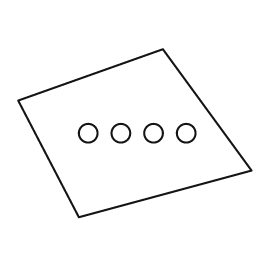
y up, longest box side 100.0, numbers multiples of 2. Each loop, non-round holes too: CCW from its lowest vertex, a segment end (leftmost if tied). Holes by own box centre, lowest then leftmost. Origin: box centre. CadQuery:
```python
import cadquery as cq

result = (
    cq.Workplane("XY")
    .moveTo(-24.0, -36.0)
    .lineTo(50.0, -16.0)
    .lineTo(12.0, 36.0)
    .lineTo(-50.0, 14.0)
    .close()
    .moveTo(-20.0, 0.0)
    .circle(4.0)
    .moveTo(-6.0, 0.0)
    .circle(4.0)
    .moveTo(8.0, 0.0)
    .circle(4.0)
    .moveTo(22.0, 0.0)
    .circle(4.0)
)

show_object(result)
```